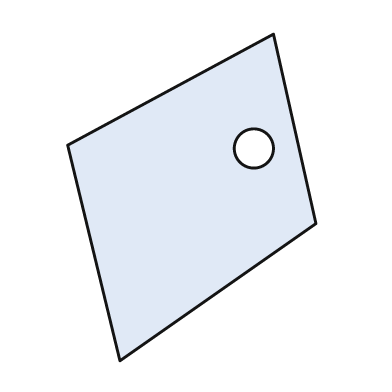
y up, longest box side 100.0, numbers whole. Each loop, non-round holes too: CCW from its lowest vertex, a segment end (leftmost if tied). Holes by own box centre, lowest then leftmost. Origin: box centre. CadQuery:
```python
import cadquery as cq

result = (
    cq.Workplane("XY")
    .moveTo(-22.0, -50.0)
    .lineTo(38.0, -8.0)
    .lineTo(25.0, 50.0)
    .lineTo(-38.0, 16.0)
    .close()
    .moveTo(19.0, 15.0)
    .circle(6.0)
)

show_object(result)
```